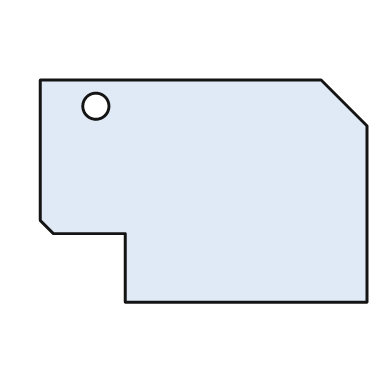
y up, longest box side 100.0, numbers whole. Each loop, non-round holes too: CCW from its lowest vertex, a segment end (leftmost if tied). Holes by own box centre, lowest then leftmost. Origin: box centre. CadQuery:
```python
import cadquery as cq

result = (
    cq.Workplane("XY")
    .moveTo(-24.0, -34.0)
    .lineTo(50.0, -34.0)
    .lineTo(50.0, 20.0)
    .lineTo(36.0, 34.0)
    .lineTo(-50.0, 34.0)
    .lineTo(-50.0, -9.0)
    .lineTo(-46.0, -13.0)
    .lineTo(-24.0, -13.0)
    .close()
    .moveTo(-33.0, 26.0)
    .circle(4.0)
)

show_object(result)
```